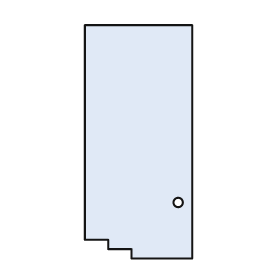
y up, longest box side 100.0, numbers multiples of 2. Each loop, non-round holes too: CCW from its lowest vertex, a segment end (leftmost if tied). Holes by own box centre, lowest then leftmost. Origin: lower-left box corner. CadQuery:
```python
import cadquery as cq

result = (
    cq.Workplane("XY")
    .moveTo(20.0, 0.0)
    .lineTo(46.0, 0.0)
    .lineTo(46.0, 100.0)
    .lineTo(0.0, 100.0)
    .lineTo(0.0, 8.0)
    .lineTo(10.0, 8.0)
    .lineTo(10.0, 4.0)
    .lineTo(20.0, 4.0)
    .close()
    .moveTo(40.0, 24.0)
    .circle(2.0)
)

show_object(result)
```